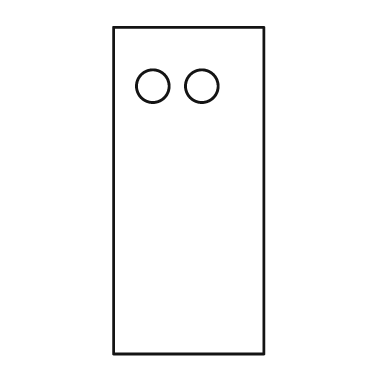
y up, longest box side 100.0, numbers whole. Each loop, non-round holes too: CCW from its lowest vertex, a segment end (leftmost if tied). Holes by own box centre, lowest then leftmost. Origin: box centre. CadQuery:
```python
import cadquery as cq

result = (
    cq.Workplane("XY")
    .moveTo(-23.0, -50.0)
    .lineTo(23.0, -50.0)
    .lineTo(23.0, 50.0)
    .lineTo(-23.0, 50.0)
    .close()
    .moveTo(-11.0, 32.0)
    .circle(5.0)
    .moveTo(4.0, 32.0)
    .circle(5.0)
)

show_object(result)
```